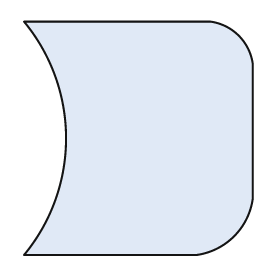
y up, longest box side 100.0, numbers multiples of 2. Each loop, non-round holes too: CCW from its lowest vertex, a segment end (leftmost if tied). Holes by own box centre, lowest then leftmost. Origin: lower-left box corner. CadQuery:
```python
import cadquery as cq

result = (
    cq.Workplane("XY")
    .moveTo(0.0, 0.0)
    .lineTo(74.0, 0.0)
    .threePointArc((90.0, 8.0), (98.0, 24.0))
    .lineTo(98.0, 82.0)
    .threePointArc((92.0, 94.0), (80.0, 100.0))
    .lineTo(0.0, 100.0)
    .threePointArc((18.0, 50.0), (0.0, 0.0))
    .close()
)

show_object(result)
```